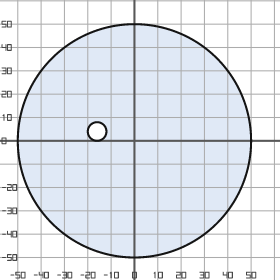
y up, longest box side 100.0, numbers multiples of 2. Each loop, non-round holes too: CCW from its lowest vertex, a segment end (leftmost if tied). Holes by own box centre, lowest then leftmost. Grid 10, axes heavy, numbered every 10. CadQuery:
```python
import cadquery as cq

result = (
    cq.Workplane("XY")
    .moveTo(0.0, 0.0)
    .circle(50.0)
    .moveTo(-16.0, 4.0)
    .circle(4.0)
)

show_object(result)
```